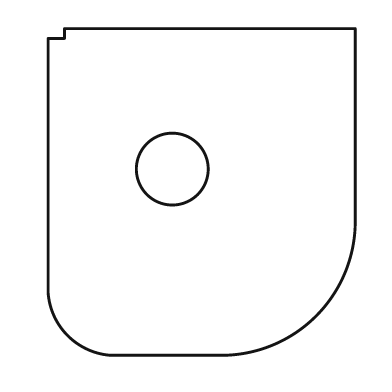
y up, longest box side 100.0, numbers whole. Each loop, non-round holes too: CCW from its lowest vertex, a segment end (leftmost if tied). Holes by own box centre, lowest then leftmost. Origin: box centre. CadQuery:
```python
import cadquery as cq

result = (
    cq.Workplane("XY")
    .moveTo(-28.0, -50.0)
    .lineTo(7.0, -50.0)
    .threePointArc((35.0, -38.0), (47.0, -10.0))
    .lineTo(47.0, 50.0)
    .lineTo(-42.0, 50.0)
    .lineTo(-42.0, 47.0)
    .lineTo(-47.0, 47.0)
    .lineTo(-47.0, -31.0)
    .threePointArc((-41.0, -44.0), (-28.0, -50.0))
    .close()
    .moveTo(-9.0, 7.0)
    .circle(11.0)
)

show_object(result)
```